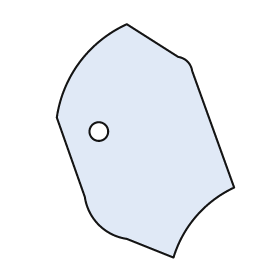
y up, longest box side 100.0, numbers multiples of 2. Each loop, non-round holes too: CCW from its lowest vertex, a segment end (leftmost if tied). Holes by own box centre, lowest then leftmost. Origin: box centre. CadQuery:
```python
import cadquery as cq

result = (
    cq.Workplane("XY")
    .moveTo(12.0, -50.0)
    .threePointArc((22.0, -32.0), (38.0, -20.0))
    .lineTo(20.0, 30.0)
    .threePointArc((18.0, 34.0), (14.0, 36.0))
    .lineTo(-8.0, 50.0)
    .threePointArc((-28.0, 34.0), (-38.0, 10.0))
    .lineTo(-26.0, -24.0)
    .threePointArc((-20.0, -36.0), (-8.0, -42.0))
    .close()
    .moveTo(-20.0, 4.0)
    .circle(4.0)
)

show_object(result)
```